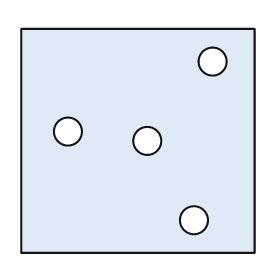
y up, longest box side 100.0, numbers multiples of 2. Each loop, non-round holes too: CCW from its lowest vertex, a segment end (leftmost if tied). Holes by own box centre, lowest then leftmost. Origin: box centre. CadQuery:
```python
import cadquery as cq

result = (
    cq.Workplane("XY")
    .moveTo(-50.0, -48.0)
    .lineTo(50.0, -48.0)
    .lineTo(50.0, 48.0)
    .lineTo(-50.0, 48.0)
    .close()
    .moveTo(24.0, -34.0)
    .circle(6.0)
    .moveTo(4.0, 0.0)
    .circle(6.0)
    .moveTo(-30.0, 4.0)
    .circle(6.0)
    .moveTo(32.0, 34.0)
    .circle(6.0)
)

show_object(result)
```